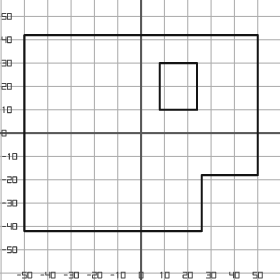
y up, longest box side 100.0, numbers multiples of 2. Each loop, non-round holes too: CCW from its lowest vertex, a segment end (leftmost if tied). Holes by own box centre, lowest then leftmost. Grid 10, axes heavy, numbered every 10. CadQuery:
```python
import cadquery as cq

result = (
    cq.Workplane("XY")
    .moveTo(-50.0, -42.0)
    .lineTo(26.0, -42.0)
    .lineTo(26.0, -18.0)
    .lineTo(50.0, -18.0)
    .lineTo(50.0, 42.0)
    .lineTo(-50.0, 42.0)
    .close()
    .moveTo(8.0, 10.0)
    .lineTo(24.0, 10.0)
    .lineTo(24.0, 30.0)
    .lineTo(8.0, 30.0)
    .close()
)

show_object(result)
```